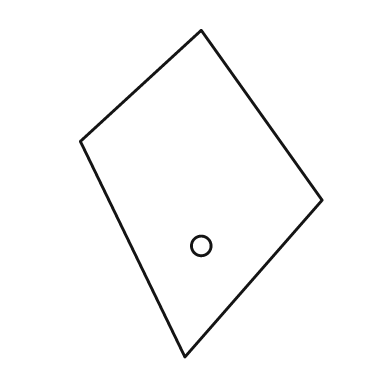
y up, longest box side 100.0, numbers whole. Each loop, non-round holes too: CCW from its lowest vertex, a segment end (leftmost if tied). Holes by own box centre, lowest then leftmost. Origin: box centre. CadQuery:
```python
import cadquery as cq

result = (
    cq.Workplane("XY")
    .moveTo(-5.0, -50.0)
    .lineTo(37.0, -2.0)
    .lineTo(0.0, 50.0)
    .lineTo(-37.0, 16.0)
    .close()
    .moveTo(0.0, -16.0)
    .circle(3.0)
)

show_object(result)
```